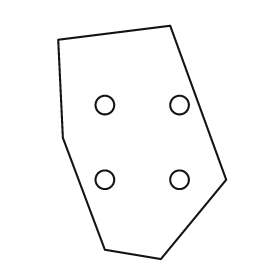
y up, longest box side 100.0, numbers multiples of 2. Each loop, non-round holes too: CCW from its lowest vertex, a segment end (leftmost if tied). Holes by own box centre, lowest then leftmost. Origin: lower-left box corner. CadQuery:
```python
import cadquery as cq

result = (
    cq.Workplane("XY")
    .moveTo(44.0, 0.0)
    .lineTo(72.0, 34.0)
    .lineTo(48.0, 100.0)
    .lineTo(0.0, 94.0)
    .lineTo(2.0, 52.0)
    .lineTo(20.0, 4.0)
    .close()
    .moveTo(20.0, 34.0)
    .circle(4.0)
    .moveTo(52.0, 34.0)
    .circle(4.0)
    .moveTo(20.0, 66.0)
    .circle(4.0)
    .moveTo(52.0, 66.0)
    .circle(4.0)
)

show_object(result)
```